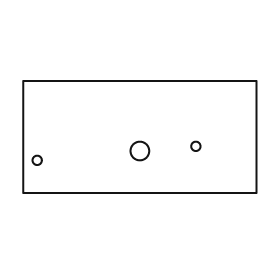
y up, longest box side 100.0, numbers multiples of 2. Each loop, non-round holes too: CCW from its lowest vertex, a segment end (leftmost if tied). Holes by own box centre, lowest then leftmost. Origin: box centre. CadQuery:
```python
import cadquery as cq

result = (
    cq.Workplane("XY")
    .moveTo(-50.0, -24.0)
    .lineTo(50.0, -24.0)
    .lineTo(50.0, 24.0)
    .lineTo(-50.0, 24.0)
    .close()
    .moveTo(-44.0, -10.0)
    .circle(2.0)
    .moveTo(0.0, -6.0)
    .circle(4.0)
    .moveTo(24.0, -4.0)
    .circle(2.0)
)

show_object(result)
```